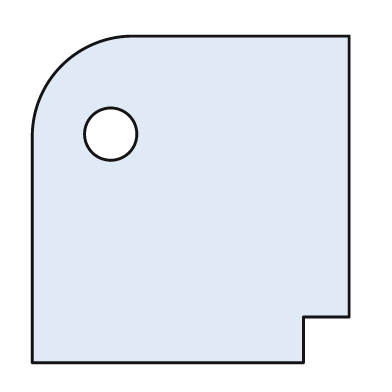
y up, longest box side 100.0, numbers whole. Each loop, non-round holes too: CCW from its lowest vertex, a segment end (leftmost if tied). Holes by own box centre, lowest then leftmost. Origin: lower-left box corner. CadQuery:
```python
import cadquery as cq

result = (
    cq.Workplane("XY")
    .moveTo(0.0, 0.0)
    .lineTo(83.0, 0.0)
    .lineTo(83.0, 14.0)
    .lineTo(97.0, 14.0)
    .lineTo(97.0, 100.0)
    .lineTo(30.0, 100.0)
    .threePointArc((9.0, 91.0), (0.0, 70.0))
    .close()
    .moveTo(24.0, 70.0)
    .circle(8.0)
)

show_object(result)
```